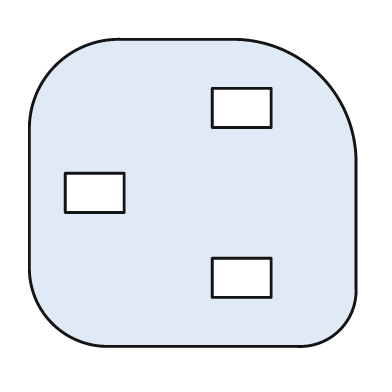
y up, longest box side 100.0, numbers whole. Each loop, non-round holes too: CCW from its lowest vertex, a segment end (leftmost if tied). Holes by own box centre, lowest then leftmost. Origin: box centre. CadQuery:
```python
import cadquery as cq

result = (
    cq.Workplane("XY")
    .moveTo(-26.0, -47.0)
    .lineTo(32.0, -47.0)
    .threePointArc((45.0, -42.0), (50.0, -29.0))
    .lineTo(50.0, 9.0)
    .threePointArc((39.0, 36.0), (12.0, 47.0))
    .lineTo(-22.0, 47.0)
    .threePointArc((-42.0, 39.0), (-50.0, 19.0))
    .lineTo(-50.0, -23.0)
    .threePointArc((-43.0, -40.0), (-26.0, -47.0))
    .close()
    .moveTo(6.0, -32.0)
    .lineTo(24.0, -32.0)
    .lineTo(24.0, -20.0)
    .lineTo(6.0, -20.0)
    .close()
    .moveTo(-39.0, -6.0)
    .lineTo(-21.0, -6.0)
    .lineTo(-21.0, 6.0)
    .lineTo(-39.0, 6.0)
    .close()
    .moveTo(6.0, 20.0)
    .lineTo(24.0, 20.0)
    .lineTo(24.0, 32.0)
    .lineTo(6.0, 32.0)
    .close()
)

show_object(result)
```